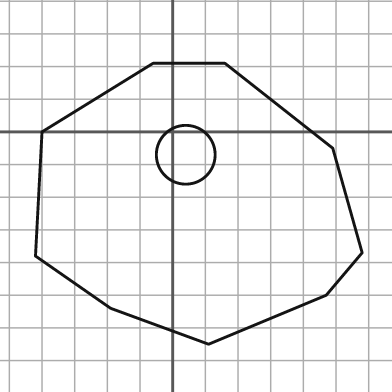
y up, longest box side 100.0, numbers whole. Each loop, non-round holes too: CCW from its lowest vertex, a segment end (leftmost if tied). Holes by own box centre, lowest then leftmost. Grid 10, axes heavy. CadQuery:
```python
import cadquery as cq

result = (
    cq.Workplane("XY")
    .moveTo(11.0, -65.0)
    .lineTo(47.0, -50.0)
    .lineTo(58.0, -37.0)
    .lineTo(49.0, -5.0)
    .lineTo(16.0, 21.0)
    .lineTo(-6.0, 21.0)
    .lineTo(-40.0, 0.0)
    .lineTo(-42.0, -38.0)
    .lineTo(-19.0, -54.0)
    .close()
    .moveTo(4.0, -7.0)
    .circle(9.0)
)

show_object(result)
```